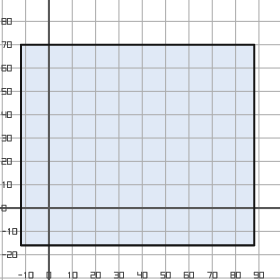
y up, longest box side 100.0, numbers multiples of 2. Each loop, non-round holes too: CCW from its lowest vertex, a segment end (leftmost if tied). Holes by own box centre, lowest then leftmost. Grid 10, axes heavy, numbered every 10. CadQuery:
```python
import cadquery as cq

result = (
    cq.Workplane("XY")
    .moveTo(-12.0, -16.0)
    .lineTo(88.0, -16.0)
    .lineTo(88.0, 70.0)
    .lineTo(-12.0, 70.0)
    .close()
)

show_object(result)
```